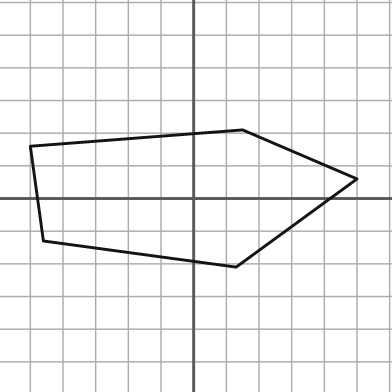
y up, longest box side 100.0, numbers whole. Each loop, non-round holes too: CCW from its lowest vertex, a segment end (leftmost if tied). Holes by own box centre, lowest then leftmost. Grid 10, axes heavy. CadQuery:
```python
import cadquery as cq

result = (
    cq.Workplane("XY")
    .moveTo(13.0, -21.0)
    .lineTo(50.0, 6.0)
    .lineTo(15.0, 21.0)
    .lineTo(-50.0, 16.0)
    .lineTo(-46.0, -13.0)
    .close()
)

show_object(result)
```